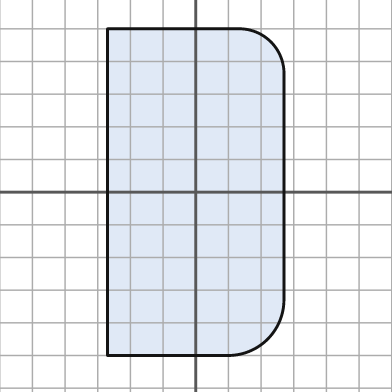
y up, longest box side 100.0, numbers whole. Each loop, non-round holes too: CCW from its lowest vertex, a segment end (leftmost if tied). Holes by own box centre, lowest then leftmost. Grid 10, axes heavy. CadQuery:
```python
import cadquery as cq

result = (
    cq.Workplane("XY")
    .moveTo(-27.0, -50.0)
    .lineTo(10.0, -50.0)
    .threePointArc((22.0, -45.0), (27.0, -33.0))
    .lineTo(27.0, 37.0)
    .threePointArc((23.0, 46.0), (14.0, 50.0))
    .lineTo(-27.0, 50.0)
    .close()
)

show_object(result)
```